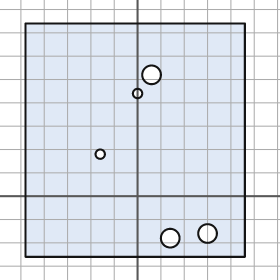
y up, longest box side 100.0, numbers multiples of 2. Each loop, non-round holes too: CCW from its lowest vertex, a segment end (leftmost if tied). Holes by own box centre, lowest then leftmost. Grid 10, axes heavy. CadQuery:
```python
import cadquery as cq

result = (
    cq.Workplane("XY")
    .moveTo(-48.0, -26.0)
    .lineTo(46.0, -26.0)
    .lineTo(46.0, 74.0)
    .lineTo(-48.0, 74.0)
    .close()
    .moveTo(14.0, -18.0)
    .circle(4.0)
    .moveTo(30.0, -16.0)
    .circle(4.0)
    .moveTo(-16.0, 18.0)
    .circle(2.0)
    .moveTo(0.0, 44.0)
    .circle(2.0)
    .moveTo(6.0, 52.0)
    .circle(4.0)
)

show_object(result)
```